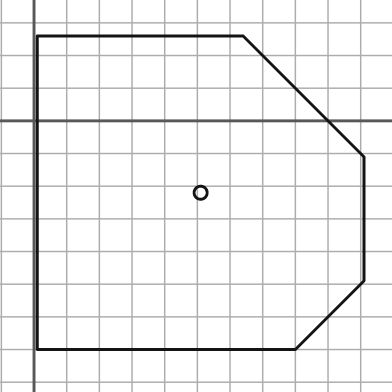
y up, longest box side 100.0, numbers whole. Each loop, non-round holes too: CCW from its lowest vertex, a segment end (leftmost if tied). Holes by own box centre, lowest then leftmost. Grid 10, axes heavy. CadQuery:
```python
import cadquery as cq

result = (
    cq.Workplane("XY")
    .moveTo(1.0, -70.0)
    .lineTo(80.0, -70.0)
    .lineTo(101.0, -49.0)
    .lineTo(101.0, -11.0)
    .lineTo(64.0, 26.0)
    .lineTo(1.0, 26.0)
    .close()
    .moveTo(51.0, -22.0)
    .circle(2.0)
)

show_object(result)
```